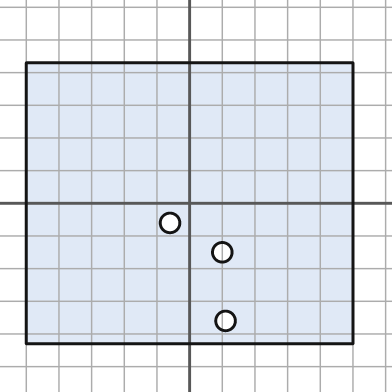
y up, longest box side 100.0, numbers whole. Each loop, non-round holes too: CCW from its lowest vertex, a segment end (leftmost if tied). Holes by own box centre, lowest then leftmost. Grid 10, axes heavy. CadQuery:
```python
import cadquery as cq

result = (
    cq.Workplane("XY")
    .moveTo(-50.0, -43.0)
    .lineTo(50.0, -43.0)
    .lineTo(50.0, 43.0)
    .lineTo(-50.0, 43.0)
    .close()
    .moveTo(11.0, -36.0)
    .circle(3.0)
    .moveTo(10.0, -15.0)
    .circle(3.0)
    .moveTo(-6.0, -6.0)
    .circle(3.0)
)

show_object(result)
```